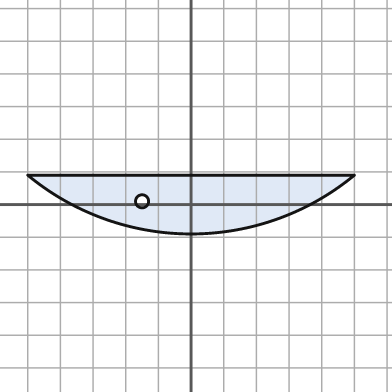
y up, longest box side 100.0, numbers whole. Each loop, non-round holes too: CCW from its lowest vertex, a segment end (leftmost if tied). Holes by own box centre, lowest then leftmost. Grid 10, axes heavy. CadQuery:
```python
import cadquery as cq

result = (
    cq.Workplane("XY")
    .moveTo(-50.0, 9.0)
    .threePointArc((0.0, -9.0), (50.0, 9.0))
    .close()
    .moveTo(-15.0, 1.0)
    .circle(2.0)
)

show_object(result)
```